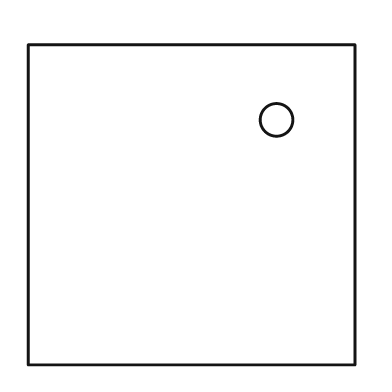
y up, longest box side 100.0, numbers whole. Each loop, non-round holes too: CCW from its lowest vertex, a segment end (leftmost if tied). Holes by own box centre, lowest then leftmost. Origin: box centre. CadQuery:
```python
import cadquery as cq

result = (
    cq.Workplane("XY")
    .moveTo(-50.0, -49.0)
    .lineTo(50.0, -49.0)
    .lineTo(50.0, 49.0)
    .lineTo(-50.0, 49.0)
    .close()
    .moveTo(26.0, 26.0)
    .circle(5.0)
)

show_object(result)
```